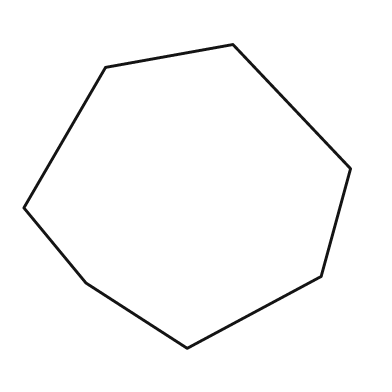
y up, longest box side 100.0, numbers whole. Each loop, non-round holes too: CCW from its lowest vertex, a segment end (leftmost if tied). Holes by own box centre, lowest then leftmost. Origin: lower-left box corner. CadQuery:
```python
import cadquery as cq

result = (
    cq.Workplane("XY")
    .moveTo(50.0, 0.0)
    .lineTo(91.0, 22.0)
    .lineTo(100.0, 55.0)
    .lineTo(64.0, 93.0)
    .lineTo(25.0, 86.0)
    .lineTo(0.0, 43.0)
    .lineTo(19.0, 20.0)
    .close()
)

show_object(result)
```